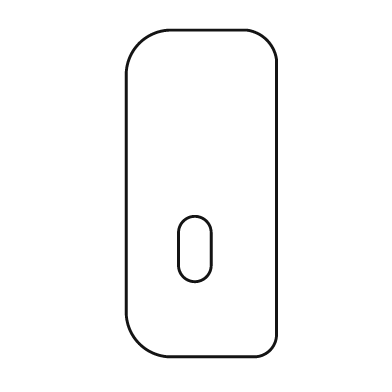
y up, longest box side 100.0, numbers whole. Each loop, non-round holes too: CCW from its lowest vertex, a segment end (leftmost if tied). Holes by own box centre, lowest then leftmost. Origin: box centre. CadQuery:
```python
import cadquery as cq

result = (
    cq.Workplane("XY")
    .moveTo(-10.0, -50.0)
    .lineTo(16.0, -50.0)
    .threePointArc((21.0, -48.0), (23.0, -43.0))
    .lineTo(23.0, 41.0)
    .threePointArc((20.0, 47.0), (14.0, 50.0))
    .lineTo(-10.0, 50.0)
    .threePointArc((-19.0, 46.0), (-23.0, 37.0))
    .lineTo(-23.0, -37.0)
    .threePointArc((-19.0, -46.0), (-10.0, -50.0))
    .close()
    .moveTo(-7.0, -22.0)
    .threePointArc((-2.0, -27.0), (3.0, -22.0))
    .lineTo(3.0, -12.0)
    .threePointArc((-2.0, -7.0), (-7.0, -12.0))
    .close()
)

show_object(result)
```